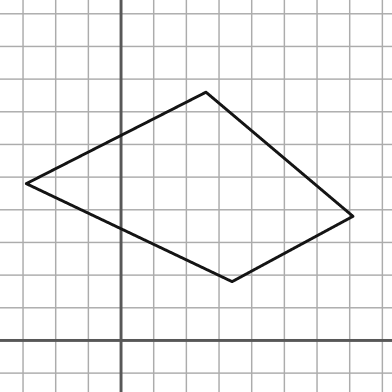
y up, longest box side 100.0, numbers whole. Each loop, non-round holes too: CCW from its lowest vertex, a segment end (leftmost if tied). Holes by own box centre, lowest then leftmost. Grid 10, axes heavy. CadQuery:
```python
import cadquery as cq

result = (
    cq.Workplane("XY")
    .moveTo(34.0, 18.0)
    .lineTo(71.0, 38.0)
    .lineTo(26.0, 76.0)
    .lineTo(-29.0, 48.0)
    .close()
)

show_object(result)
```